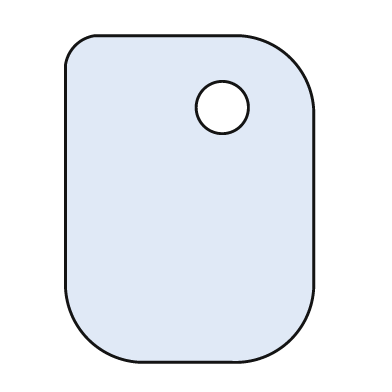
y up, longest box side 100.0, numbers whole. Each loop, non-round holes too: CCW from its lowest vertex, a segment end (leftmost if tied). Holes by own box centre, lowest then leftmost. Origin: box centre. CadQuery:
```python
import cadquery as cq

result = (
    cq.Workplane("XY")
    .moveTo(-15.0, -50.0)
    .lineTo(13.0, -50.0)
    .threePointArc((31.0, -43.0), (38.0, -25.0))
    .lineTo(38.0, 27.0)
    .threePointArc((31.0, 43.0), (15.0, 50.0))
    .lineTo(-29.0, 50.0)
    .threePointArc((-35.0, 47.0), (-38.0, 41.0))
    .lineTo(-38.0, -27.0)
    .threePointArc((-31.0, -43.0), (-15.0, -50.0))
    .close()
    .moveTo(10.0, 28.0)
    .circle(8.0)
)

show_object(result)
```